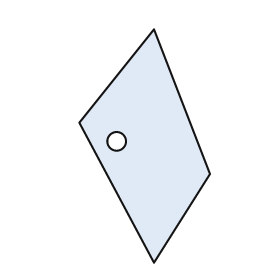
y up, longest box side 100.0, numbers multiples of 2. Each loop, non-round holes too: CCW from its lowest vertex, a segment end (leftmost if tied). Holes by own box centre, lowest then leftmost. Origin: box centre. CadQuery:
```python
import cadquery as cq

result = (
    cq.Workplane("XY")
    .moveTo(4.0, -50.0)
    .lineTo(28.0, -12.0)
    .lineTo(4.0, 50.0)
    .lineTo(-28.0, 10.0)
    .close()
    .moveTo(-12.0, 2.0)
    .circle(4.0)
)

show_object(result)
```